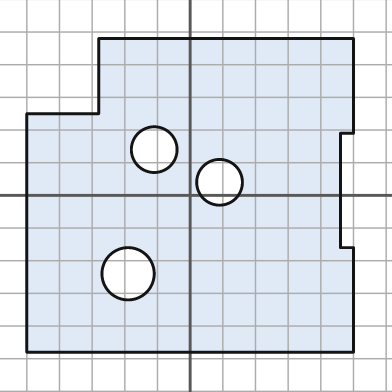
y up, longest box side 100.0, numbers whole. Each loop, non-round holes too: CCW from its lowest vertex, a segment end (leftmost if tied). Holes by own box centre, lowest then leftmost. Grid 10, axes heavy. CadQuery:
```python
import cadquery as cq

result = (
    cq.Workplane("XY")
    .moveTo(-50.0, -48.0)
    .lineTo(50.0, -48.0)
    .lineTo(50.0, -16.0)
    .lineTo(46.0, -16.0)
    .lineTo(46.0, 19.0)
    .lineTo(50.0, 19.0)
    .lineTo(50.0, 48.0)
    .lineTo(-28.0, 48.0)
    .lineTo(-28.0, 25.0)
    .lineTo(-50.0, 25.0)
    .close()
    .moveTo(-19.0, -24.0)
    .circle(8.0)
    .moveTo(9.0, 4.0)
    .circle(7.0)
    .moveTo(-11.0, 14.0)
    .circle(7.0)
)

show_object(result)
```